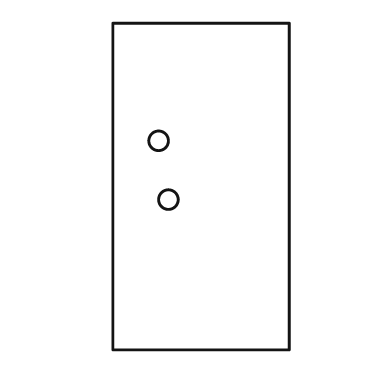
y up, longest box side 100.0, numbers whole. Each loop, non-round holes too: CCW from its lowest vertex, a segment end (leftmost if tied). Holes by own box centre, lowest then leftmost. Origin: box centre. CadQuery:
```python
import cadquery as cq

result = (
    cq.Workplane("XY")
    .moveTo(-27.0, -50.0)
    .lineTo(27.0, -50.0)
    .lineTo(27.0, 50.0)
    .lineTo(-27.0, 50.0)
    .close()
    .moveTo(-10.0, -4.0)
    .circle(3.0)
    .moveTo(-13.0, 14.0)
    .circle(3.0)
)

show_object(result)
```